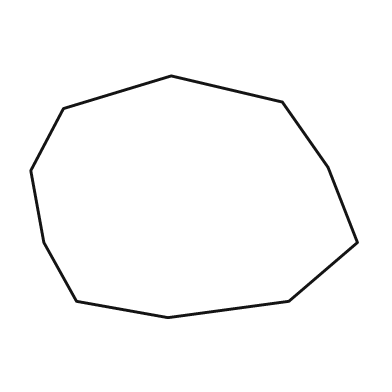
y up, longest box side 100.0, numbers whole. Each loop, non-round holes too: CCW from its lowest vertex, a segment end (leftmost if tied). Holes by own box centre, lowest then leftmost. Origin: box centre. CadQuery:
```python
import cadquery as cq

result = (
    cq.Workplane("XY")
    .moveTo(-8.0, -37.0)
    .lineTo(29.0, -32.0)
    .lineTo(50.0, -14.0)
    .lineTo(41.0, 9.0)
    .lineTo(27.0, 29.0)
    .lineTo(-7.0, 37.0)
    .lineTo(-40.0, 27.0)
    .lineTo(-50.0, 8.0)
    .lineTo(-46.0, -14.0)
    .lineTo(-36.0, -32.0)
    .close()
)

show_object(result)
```